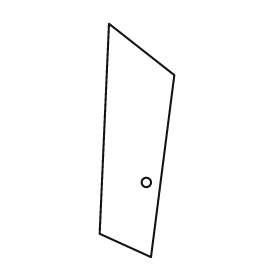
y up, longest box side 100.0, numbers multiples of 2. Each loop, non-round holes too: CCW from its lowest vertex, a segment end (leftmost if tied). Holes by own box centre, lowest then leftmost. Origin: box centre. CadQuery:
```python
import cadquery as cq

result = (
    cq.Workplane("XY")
    .moveTo(6.0, -50.0)
    .lineTo(16.0, 28.0)
    .lineTo(-12.0, 50.0)
    .lineTo(-16.0, -40.0)
    .close()
    .moveTo(4.0, -18.0)
    .circle(2.0)
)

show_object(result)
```